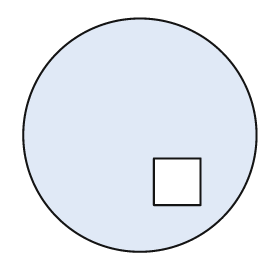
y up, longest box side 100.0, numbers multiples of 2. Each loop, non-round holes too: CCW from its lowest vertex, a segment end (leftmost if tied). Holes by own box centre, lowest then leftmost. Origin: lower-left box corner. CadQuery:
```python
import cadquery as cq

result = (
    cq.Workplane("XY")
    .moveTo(50.0, 50.0)
    .circle(50.0)
    .moveTo(56.0, 20.0)
    .lineTo(76.0, 20.0)
    .lineTo(76.0, 40.0)
    .lineTo(56.0, 40.0)
    .close()
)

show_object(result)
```